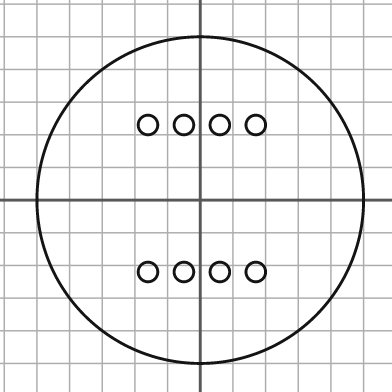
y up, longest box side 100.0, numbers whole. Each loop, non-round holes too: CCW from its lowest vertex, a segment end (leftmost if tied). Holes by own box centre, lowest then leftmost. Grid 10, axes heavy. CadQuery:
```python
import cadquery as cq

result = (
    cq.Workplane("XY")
    .moveTo(0.0, 0.0)
    .circle(50.0)
    .moveTo(-16.0, -22.0)
    .circle(3.0)
    .moveTo(-5.0, -22.0)
    .circle(3.0)
    .moveTo(6.0, -22.0)
    .circle(3.0)
    .moveTo(17.0, -22.0)
    .circle(3.0)
    .moveTo(-16.0, 23.0)
    .circle(3.0)
    .moveTo(-5.0, 23.0)
    .circle(3.0)
    .moveTo(6.0, 23.0)
    .circle(3.0)
    .moveTo(17.0, 23.0)
    .circle(3.0)
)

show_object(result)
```